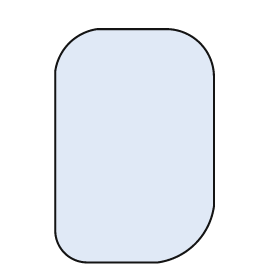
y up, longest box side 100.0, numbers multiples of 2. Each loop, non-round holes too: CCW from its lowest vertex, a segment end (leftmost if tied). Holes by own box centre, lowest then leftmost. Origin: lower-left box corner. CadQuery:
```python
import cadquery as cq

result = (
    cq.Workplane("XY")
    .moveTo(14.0, 0.0)
    .lineTo(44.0, 0.0)
    .threePointArc((60.0, 8.0), (68.0, 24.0))
    .lineTo(68.0, 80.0)
    .threePointArc((62.0, 94.0), (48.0, 100.0))
    .lineTo(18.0, 100.0)
    .threePointArc((6.0, 94.0), (0.0, 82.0))
    .lineTo(0.0, 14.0)
    .threePointArc((4.0, 4.0), (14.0, 0.0))
    .close()
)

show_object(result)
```